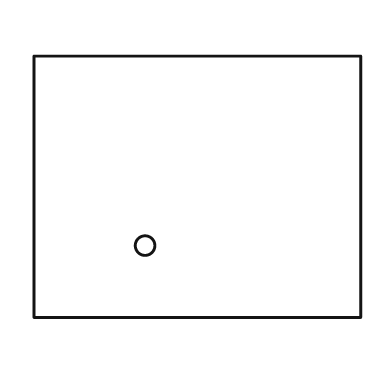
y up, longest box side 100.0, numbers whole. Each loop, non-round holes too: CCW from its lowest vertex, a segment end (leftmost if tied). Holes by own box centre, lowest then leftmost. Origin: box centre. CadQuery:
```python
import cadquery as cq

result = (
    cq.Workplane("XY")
    .moveTo(-50.0, -40.0)
    .lineTo(50.0, -40.0)
    .lineTo(50.0, 40.0)
    .lineTo(-50.0, 40.0)
    .close()
    .moveTo(-16.0, -18.0)
    .circle(3.0)
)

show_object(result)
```